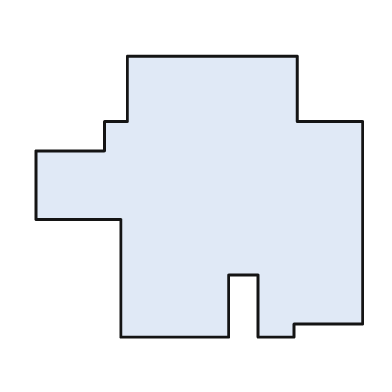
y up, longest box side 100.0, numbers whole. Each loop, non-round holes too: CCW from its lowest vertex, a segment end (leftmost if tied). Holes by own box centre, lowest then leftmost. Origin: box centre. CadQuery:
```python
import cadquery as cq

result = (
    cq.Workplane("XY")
    .moveTo(-24.0, -43.0)
    .lineTo(9.0, -43.0)
    .lineTo(9.0, -24.0)
    .lineTo(18.0, -24.0)
    .lineTo(18.0, -43.0)
    .lineTo(29.0, -43.0)
    .lineTo(29.0, -39.0)
    .lineTo(50.0, -39.0)
    .lineTo(50.0, 23.0)
    .lineTo(30.0, 23.0)
    .lineTo(30.0, 43.0)
    .lineTo(-22.0, 43.0)
    .lineTo(-22.0, 23.0)
    .lineTo(-29.0, 23.0)
    .lineTo(-29.0, 14.0)
    .lineTo(-50.0, 14.0)
    .lineTo(-50.0, -7.0)
    .lineTo(-24.0, -7.0)
    .close()
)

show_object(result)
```